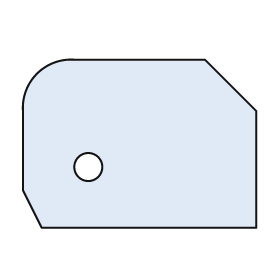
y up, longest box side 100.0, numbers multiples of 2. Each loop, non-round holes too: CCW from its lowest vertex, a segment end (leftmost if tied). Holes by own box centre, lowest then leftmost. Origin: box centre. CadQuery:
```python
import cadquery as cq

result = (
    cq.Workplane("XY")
    .moveTo(-42.0, -36.0)
    .lineTo(50.0, -36.0)
    .lineTo(50.0, 14.0)
    .lineTo(28.0, 36.0)
    .lineTo(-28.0, 36.0)
    .threePointArc((-44.0, 30.0), (-50.0, 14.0))
    .lineTo(-50.0, -20.0)
    .close()
    .moveTo(-22.0, -10.0)
    .circle(6.0)
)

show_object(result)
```